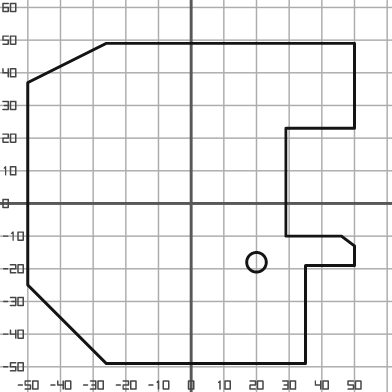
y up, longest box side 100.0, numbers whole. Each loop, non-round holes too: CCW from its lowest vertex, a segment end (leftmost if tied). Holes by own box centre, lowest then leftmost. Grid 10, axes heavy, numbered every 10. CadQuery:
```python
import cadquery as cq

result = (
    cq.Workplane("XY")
    .moveTo(-26.0, -49.0)
    .lineTo(35.0, -49.0)
    .lineTo(35.0, -19.0)
    .lineTo(50.0, -19.0)
    .lineTo(50.0, -13.0)
    .lineTo(46.0, -10.0)
    .lineTo(29.0, -10.0)
    .lineTo(29.0, 23.0)
    .lineTo(50.0, 23.0)
    .lineTo(50.0, 49.0)
    .lineTo(-26.0, 49.0)
    .lineTo(-50.0, 37.0)
    .lineTo(-50.0, -25.0)
    .close()
    .moveTo(20.0, -18.0)
    .circle(3.0)
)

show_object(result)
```